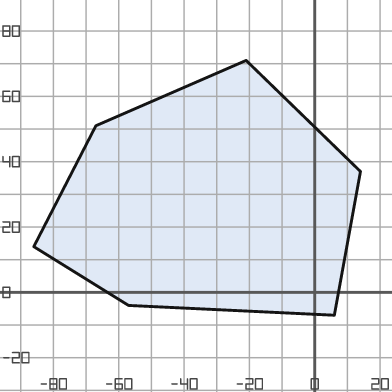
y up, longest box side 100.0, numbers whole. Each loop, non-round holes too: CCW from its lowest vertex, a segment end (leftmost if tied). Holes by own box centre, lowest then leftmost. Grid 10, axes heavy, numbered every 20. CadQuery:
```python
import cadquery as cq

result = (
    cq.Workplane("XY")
    .moveTo(6.0, -7.0)
    .lineTo(14.0, 37.0)
    .lineTo(-21.0, 71.0)
    .lineTo(-67.0, 51.0)
    .lineTo(-86.0, 14.0)
    .lineTo(-57.0, -4.0)
    .close()
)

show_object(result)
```